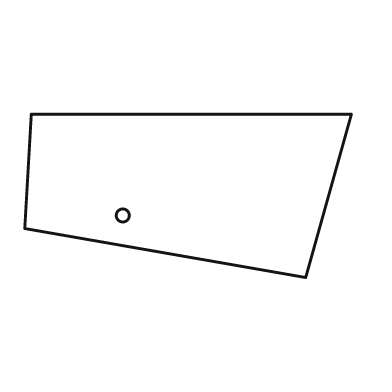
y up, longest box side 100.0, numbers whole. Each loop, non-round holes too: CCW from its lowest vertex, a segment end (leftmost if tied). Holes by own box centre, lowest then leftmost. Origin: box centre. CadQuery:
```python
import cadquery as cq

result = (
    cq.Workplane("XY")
    .moveTo(36.0, -25.0)
    .lineTo(50.0, 25.0)
    .lineTo(-48.0, 25.0)
    .lineTo(-50.0, -10.0)
    .close()
    .moveTo(-20.0, -6.0)
    .circle(2.0)
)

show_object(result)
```